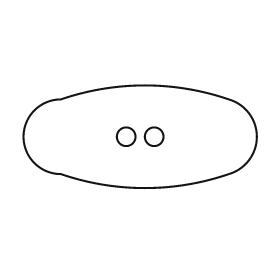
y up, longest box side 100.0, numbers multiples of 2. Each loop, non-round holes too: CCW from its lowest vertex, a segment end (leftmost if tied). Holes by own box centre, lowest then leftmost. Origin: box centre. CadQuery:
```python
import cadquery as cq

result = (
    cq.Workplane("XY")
    .moveTo(-34.0, -16.0)
    .threePointArc((2.0, -22.0), (38.0, -16.0))
    .threePointArc((50.0, 0.0), (38.0, 16.0))
    .threePointArc((2.0, 22.0), (-34.0, 16.0))
    .threePointArc((-50.0, 0.0), (-34.0, -16.0))
    .close()
    .moveTo(-6.0, 0.0)
    .circle(4.0)
    .moveTo(6.0, 0.0)
    .circle(4.0)
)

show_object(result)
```